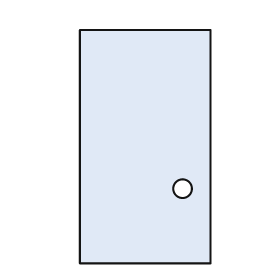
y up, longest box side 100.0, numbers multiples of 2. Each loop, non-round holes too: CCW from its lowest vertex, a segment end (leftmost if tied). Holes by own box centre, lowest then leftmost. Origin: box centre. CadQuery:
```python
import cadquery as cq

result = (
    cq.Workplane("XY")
    .moveTo(-28.0, -50.0)
    .lineTo(28.0, -50.0)
    .lineTo(28.0, 50.0)
    .lineTo(-28.0, 50.0)
    .close()
    .moveTo(16.0, -18.0)
    .circle(4.0)
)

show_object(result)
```